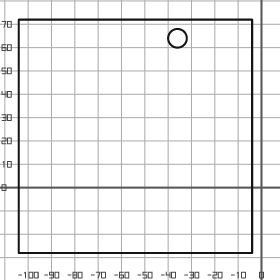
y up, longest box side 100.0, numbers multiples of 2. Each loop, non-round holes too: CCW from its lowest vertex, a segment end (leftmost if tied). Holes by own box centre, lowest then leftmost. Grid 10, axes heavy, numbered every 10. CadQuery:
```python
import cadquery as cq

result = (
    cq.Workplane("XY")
    .moveTo(-104.0, -28.0)
    .lineTo(-4.0, -28.0)
    .lineTo(-4.0, 72.0)
    .lineTo(-104.0, 72.0)
    .close()
    .moveTo(-36.0, 64.0)
    .circle(4.0)
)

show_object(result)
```